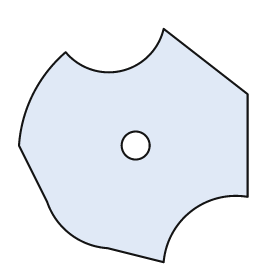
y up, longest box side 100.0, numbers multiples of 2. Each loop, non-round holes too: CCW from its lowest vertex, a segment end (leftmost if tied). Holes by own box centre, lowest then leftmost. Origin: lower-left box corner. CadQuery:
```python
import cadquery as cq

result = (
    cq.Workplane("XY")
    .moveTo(62.0, 0.0)
    .threePointArc((74.0, 22.0), (98.0, 28.0))
    .lineTo(98.0, 72.0)
    .lineTo(62.0, 100.0)
    .threePointArc((44.0, 82.0), (20.0, 90.0))
    .threePointArc((6.0, 72.0), (0.0, 50.0))
    .lineTo(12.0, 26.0)
    .threePointArc((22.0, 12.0), (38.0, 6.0))
    .close()
    .moveTo(50.0, 50.0)
    .circle(6.0)
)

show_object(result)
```